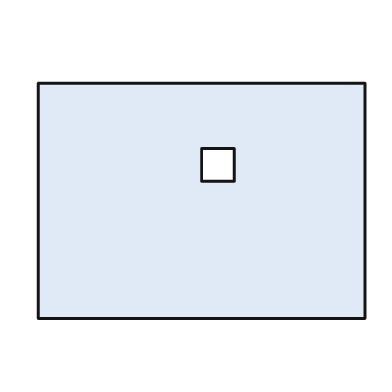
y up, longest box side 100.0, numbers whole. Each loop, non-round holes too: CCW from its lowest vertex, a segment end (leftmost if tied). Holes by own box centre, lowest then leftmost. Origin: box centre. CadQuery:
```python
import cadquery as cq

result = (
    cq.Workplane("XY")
    .moveTo(-50.0, -36.0)
    .lineTo(50.0, -36.0)
    .lineTo(50.0, 36.0)
    .lineTo(-50.0, 36.0)
    .close()
    .moveTo(0.0, 6.0)
    .lineTo(10.0, 6.0)
    .lineTo(10.0, 16.0)
    .lineTo(0.0, 16.0)
    .close()
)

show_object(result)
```